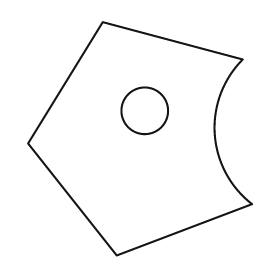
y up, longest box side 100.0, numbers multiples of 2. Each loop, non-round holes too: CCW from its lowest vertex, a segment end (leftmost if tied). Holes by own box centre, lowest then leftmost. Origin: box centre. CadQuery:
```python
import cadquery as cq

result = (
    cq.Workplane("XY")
    .moveTo(-10.0, -50.0)
    .lineTo(48.0, -28.0)
    .threePointArc((32.0, 2.0), (44.0, 34.0))
    .lineTo(-16.0, 50.0)
    .lineTo(-48.0, -2.0)
    .close()
    .moveTo(2.0, 12.0)
    .circle(10.0)
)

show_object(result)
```